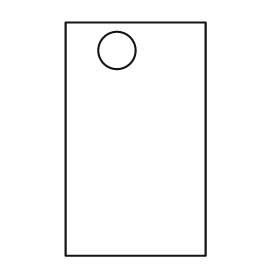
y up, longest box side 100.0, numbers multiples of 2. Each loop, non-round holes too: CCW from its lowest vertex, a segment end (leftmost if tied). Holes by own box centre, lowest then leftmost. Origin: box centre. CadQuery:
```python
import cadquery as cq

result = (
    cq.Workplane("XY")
    .moveTo(-30.0, -50.0)
    .lineTo(30.0, -50.0)
    .lineTo(30.0, 50.0)
    .lineTo(-30.0, 50.0)
    .close()
    .moveTo(-8.0, 38.0)
    .circle(8.0)
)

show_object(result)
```